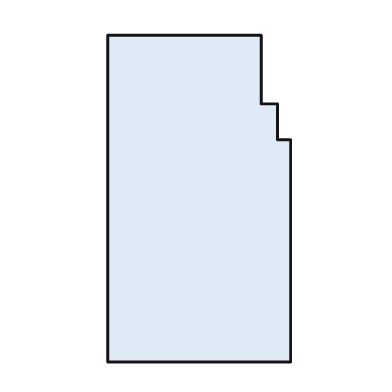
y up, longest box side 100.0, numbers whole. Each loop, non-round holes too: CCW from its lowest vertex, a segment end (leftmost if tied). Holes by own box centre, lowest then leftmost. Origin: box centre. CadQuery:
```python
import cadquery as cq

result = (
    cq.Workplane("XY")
    .moveTo(-28.0, -50.0)
    .lineTo(28.0, -50.0)
    .lineTo(28.0, 18.0)
    .lineTo(24.0, 18.0)
    .lineTo(24.0, 29.0)
    .lineTo(19.0, 29.0)
    .lineTo(19.0, 50.0)
    .lineTo(-28.0, 50.0)
    .close()
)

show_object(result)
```